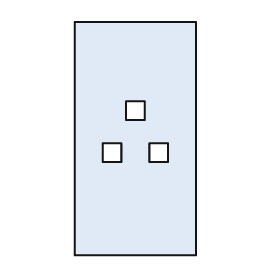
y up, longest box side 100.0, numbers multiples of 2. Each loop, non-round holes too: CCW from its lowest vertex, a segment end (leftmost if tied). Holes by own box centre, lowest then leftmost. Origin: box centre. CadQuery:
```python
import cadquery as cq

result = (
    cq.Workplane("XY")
    .moveTo(-26.0, -50.0)
    .lineTo(26.0, -50.0)
    .lineTo(26.0, 50.0)
    .lineTo(-26.0, 50.0)
    .close()
    .moveTo(-14.0, -10.0)
    .lineTo(-6.0, -10.0)
    .lineTo(-6.0, -2.0)
    .lineTo(-14.0, -2.0)
    .close()
    .moveTo(6.0, -10.0)
    .lineTo(14.0, -10.0)
    .lineTo(14.0, -2.0)
    .lineTo(6.0, -2.0)
    .close()
    .moveTo(-4.0, 8.0)
    .lineTo(4.0, 8.0)
    .lineTo(4.0, 16.0)
    .lineTo(-4.0, 16.0)
    .close()
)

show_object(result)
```